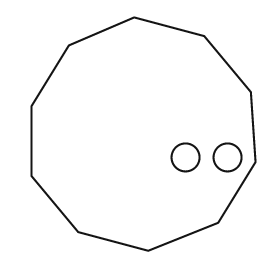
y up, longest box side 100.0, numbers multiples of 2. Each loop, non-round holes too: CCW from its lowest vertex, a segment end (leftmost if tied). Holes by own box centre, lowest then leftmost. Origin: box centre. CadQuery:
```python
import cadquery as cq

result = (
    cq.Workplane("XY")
    .moveTo(2.0, -50.0)
    .lineTo(32.0, -38.0)
    .lineTo(48.0, -12.0)
    .lineTo(46.0, 18.0)
    .lineTo(26.0, 42.0)
    .lineTo(-4.0, 50.0)
    .lineTo(-32.0, 38.0)
    .lineTo(-48.0, 12.0)
    .lineTo(-48.0, -18.0)
    .lineTo(-28.0, -42.0)
    .close()
    .moveTo(18.0, -10.0)
    .circle(6.0)
    .moveTo(36.0, -10.0)
    .circle(6.0)
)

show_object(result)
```